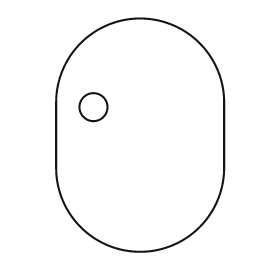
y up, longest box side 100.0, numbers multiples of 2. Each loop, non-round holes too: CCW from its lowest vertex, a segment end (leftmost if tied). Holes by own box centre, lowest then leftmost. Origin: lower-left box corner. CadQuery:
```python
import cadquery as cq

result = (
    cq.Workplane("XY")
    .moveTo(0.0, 36.0)
    .threePointArc((36.0, 0.0), (72.0, 36.0))
    .lineTo(72.0, 64.0)
    .threePointArc((36.0, 100.0), (0.0, 64.0))
    .close()
    .moveTo(16.0, 62.0)
    .circle(6.0)
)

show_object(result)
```